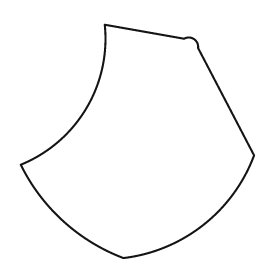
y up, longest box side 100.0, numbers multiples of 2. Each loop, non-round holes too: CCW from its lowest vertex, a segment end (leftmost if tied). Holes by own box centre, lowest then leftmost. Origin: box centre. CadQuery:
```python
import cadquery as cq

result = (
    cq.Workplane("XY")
    .moveTo(-6.0, -50.0)
    .threePointArc((28.0, -36.0), (50.0, -6.0))
    .lineTo(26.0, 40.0)
    .threePointArc((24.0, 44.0), (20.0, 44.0))
    .lineTo(-14.0, 50.0)
    .threePointArc((-22.0, 14.0), (-50.0, -10.0))
    .threePointArc((-32.0, -34.0), (-6.0, -50.0))
    .close()
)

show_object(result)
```